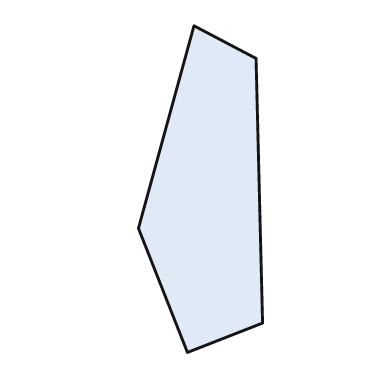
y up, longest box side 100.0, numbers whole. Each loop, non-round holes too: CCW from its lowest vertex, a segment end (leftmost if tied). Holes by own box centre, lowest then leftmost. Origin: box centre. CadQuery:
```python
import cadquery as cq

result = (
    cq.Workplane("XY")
    .moveTo(-4.0, -50.0)
    .lineTo(19.0, -41.0)
    .lineTo(17.0, 40.0)
    .lineTo(-2.0, 50.0)
    .lineTo(-19.0, -12.0)
    .close()
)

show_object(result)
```